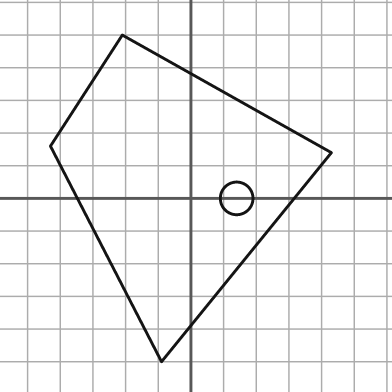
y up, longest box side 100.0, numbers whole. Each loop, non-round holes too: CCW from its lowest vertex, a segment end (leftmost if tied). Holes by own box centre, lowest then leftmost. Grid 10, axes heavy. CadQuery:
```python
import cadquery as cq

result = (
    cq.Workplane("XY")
    .moveTo(-9.0, -50.0)
    .lineTo(43.0, 14.0)
    .lineTo(-21.0, 50.0)
    .lineTo(-43.0, 16.0)
    .close()
    .moveTo(14.0, 0.0)
    .circle(5.0)
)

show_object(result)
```